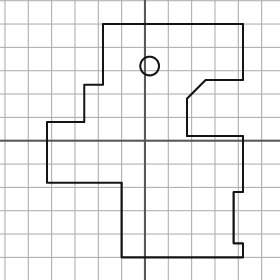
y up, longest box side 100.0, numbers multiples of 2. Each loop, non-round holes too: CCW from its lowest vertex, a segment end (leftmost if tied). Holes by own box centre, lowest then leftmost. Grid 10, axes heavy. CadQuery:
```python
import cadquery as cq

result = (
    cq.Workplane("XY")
    .moveTo(-10.0, -50.0)
    .lineTo(42.0, -50.0)
    .lineTo(42.0, -44.0)
    .lineTo(38.0, -44.0)
    .lineTo(38.0, -22.0)
    .lineTo(42.0, -22.0)
    .lineTo(42.0, 2.0)
    .lineTo(18.0, 2.0)
    .lineTo(18.0, 18.0)
    .lineTo(26.0, 26.0)
    .lineTo(42.0, 26.0)
    .lineTo(42.0, 50.0)
    .lineTo(-18.0, 50.0)
    .lineTo(-18.0, 24.0)
    .lineTo(-26.0, 24.0)
    .lineTo(-26.0, 8.0)
    .lineTo(-42.0, 8.0)
    .lineTo(-42.0, -18.0)
    .lineTo(-10.0, -18.0)
    .close()
    .moveTo(2.0, 32.0)
    .circle(4.0)
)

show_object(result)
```